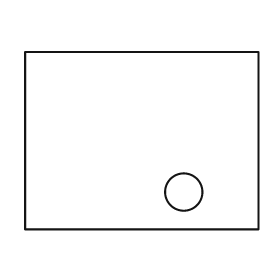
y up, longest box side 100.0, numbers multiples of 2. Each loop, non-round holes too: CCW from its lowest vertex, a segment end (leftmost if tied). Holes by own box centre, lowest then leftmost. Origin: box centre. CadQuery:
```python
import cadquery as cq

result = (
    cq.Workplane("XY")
    .moveTo(-50.0, -38.0)
    .lineTo(50.0, -38.0)
    .lineTo(50.0, 38.0)
    .lineTo(-50.0, 38.0)
    .close()
    .moveTo(18.0, -22.0)
    .circle(8.0)
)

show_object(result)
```